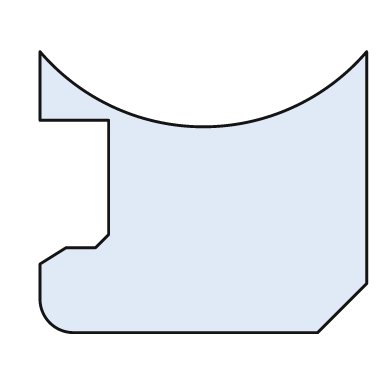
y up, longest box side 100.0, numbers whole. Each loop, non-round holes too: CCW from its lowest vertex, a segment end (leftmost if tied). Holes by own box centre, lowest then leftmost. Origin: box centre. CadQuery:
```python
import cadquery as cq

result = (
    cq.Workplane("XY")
    .moveTo(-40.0, -43.0)
    .lineTo(35.0, -43.0)
    .lineTo(50.0, -28.0)
    .lineTo(50.0, 43.0)
    .threePointArc((0.0, 20.0), (-50.0, 43.0))
    .lineTo(-50.0, 22.0)
    .lineTo(-29.0, 22.0)
    .lineTo(-29.0, -13.0)
    .lineTo(-33.0, -17.0)
    .lineTo(-42.0, -17.0)
    .lineTo(-50.0, -22.0)
    .lineTo(-50.0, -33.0)
    .threePointArc((-47.0, -40.0), (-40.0, -43.0))
    .close()
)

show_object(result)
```